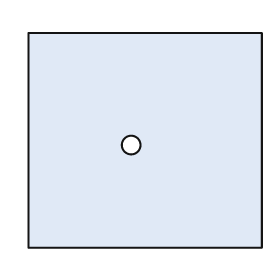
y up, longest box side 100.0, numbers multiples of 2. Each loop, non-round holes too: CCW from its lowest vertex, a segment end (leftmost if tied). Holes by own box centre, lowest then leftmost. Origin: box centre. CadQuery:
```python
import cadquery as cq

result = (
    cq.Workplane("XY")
    .moveTo(-50.0, -46.0)
    .lineTo(50.0, -46.0)
    .lineTo(50.0, 46.0)
    .lineTo(-50.0, 46.0)
    .close()
    .moveTo(-6.0, -2.0)
    .circle(4.0)
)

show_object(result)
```